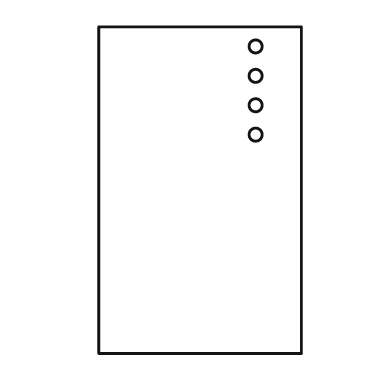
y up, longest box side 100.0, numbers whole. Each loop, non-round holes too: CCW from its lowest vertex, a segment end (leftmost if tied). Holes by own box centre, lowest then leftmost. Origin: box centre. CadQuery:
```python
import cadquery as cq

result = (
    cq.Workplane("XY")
    .moveTo(-31.0, -50.0)
    .lineTo(31.0, -50.0)
    .lineTo(31.0, 50.0)
    .lineTo(-31.0, 50.0)
    .close()
    .moveTo(17.0, 17.0)
    .circle(2.0)
    .moveTo(17.0, 26.0)
    .circle(2.0)
    .moveTo(17.0, 35.0)
    .circle(2.0)
    .moveTo(17.0, 44.0)
    .circle(2.0)
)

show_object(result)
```